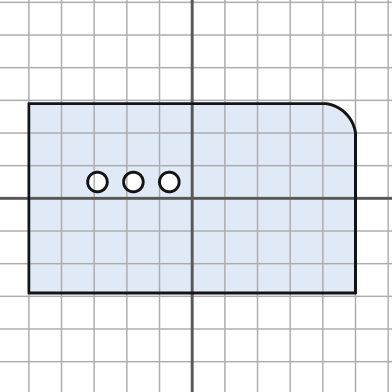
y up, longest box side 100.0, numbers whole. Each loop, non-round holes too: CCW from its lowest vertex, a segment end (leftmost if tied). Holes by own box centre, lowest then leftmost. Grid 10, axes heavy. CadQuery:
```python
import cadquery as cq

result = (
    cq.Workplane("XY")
    .moveTo(-50.0, -29.0)
    .lineTo(50.0, -29.0)
    .lineTo(50.0, 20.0)
    .threePointArc((47.0, 26.0), (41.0, 29.0))
    .lineTo(-50.0, 29.0)
    .close()
    .moveTo(-29.0, 5.0)
    .circle(3.0)
    .moveTo(-18.0, 5.0)
    .circle(3.0)
    .moveTo(-7.0, 5.0)
    .circle(3.0)
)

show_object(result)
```